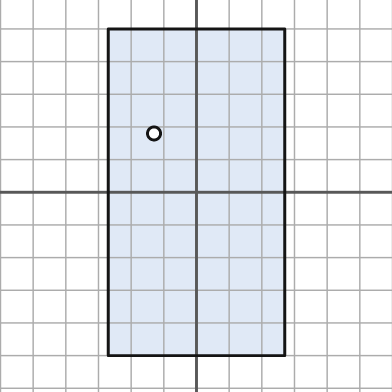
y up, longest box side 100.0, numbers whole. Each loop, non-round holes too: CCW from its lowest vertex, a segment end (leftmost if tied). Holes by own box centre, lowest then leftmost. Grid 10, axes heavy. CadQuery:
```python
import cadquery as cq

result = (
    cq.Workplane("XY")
    .moveTo(-27.0, -50.0)
    .lineTo(27.0, -50.0)
    .lineTo(27.0, 50.0)
    .lineTo(-27.0, 50.0)
    .close()
    .moveTo(-13.0, 18.0)
    .circle(2.0)
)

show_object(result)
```